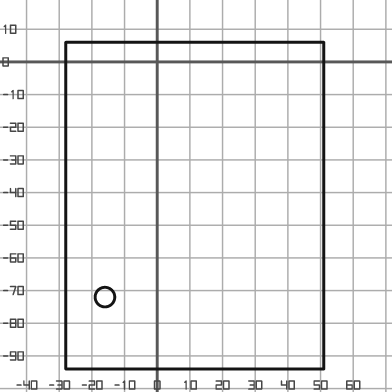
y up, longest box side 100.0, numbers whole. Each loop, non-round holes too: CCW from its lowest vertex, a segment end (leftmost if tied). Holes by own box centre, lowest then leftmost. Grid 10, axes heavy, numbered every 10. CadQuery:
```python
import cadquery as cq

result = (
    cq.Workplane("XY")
    .moveTo(-28.0, -94.0)
    .lineTo(51.0, -94.0)
    .lineTo(51.0, 6.0)
    .lineTo(-28.0, 6.0)
    .close()
    .moveTo(-16.0, -72.0)
    .circle(3.0)
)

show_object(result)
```